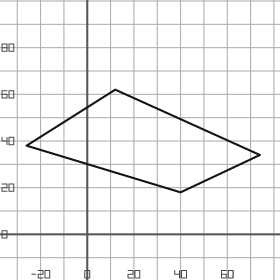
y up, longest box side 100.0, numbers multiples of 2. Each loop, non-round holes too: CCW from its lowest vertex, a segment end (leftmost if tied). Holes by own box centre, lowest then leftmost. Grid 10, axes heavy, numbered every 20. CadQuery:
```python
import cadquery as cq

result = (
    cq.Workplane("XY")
    .moveTo(40.0, 18.0)
    .lineTo(74.0, 34.0)
    .lineTo(12.0, 62.0)
    .lineTo(-26.0, 38.0)
    .close()
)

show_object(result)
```